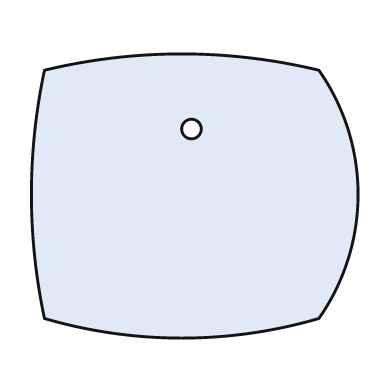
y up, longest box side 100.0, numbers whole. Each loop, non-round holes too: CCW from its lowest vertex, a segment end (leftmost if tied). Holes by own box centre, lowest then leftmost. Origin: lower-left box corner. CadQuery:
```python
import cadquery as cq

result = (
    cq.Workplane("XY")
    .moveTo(4.0, 6.0)
    .threePointArc((46.0, 0.0), (88.0, 6.0))
    .threePointArc((100.0, 44.0), (88.0, 82.0))
    .threePointArc((46.0, 87.0), (4.0, 82.0))
    .threePointArc((0.0, 44.0), (4.0, 6.0))
    .close()
    .moveTo(49.0, 64.0)
    .circle(3.0)
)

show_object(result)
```